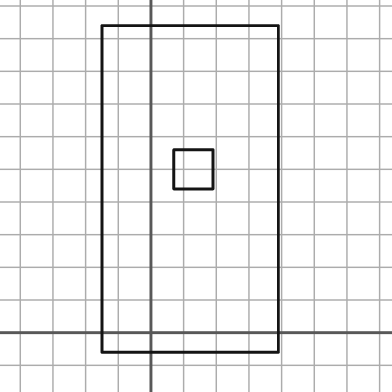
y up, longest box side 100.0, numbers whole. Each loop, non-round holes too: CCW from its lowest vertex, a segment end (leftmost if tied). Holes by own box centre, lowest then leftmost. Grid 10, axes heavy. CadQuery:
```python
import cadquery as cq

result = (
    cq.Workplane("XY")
    .moveTo(-15.0, -6.0)
    .lineTo(39.0, -6.0)
    .lineTo(39.0, 94.0)
    .lineTo(-15.0, 94.0)
    .close()
    .moveTo(7.0, 44.0)
    .lineTo(19.0, 44.0)
    .lineTo(19.0, 56.0)
    .lineTo(7.0, 56.0)
    .close()
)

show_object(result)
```